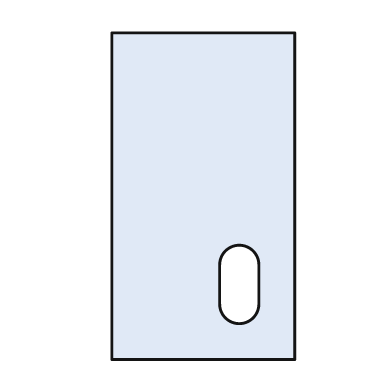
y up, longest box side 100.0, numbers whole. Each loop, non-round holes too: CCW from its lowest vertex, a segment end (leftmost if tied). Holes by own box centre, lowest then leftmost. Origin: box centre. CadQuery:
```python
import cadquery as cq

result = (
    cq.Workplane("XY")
    .moveTo(-28.0, -50.0)
    .lineTo(28.0, -50.0)
    .lineTo(28.0, 50.0)
    .lineTo(-28.0, 50.0)
    .close()
    .moveTo(5.0, -33.0)
    .threePointArc((11.0, -39.0), (17.0, -33.0))
    .lineTo(17.0, -21.0)
    .threePointArc((11.0, -15.0), (5.0, -21.0))
    .close()
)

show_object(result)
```